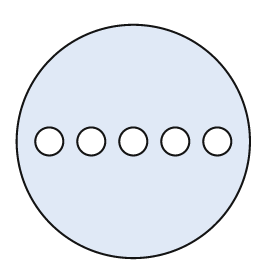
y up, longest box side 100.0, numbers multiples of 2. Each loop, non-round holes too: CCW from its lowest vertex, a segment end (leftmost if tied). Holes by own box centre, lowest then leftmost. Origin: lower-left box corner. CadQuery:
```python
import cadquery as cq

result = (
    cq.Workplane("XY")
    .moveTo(50.0, 50.0)
    .circle(50.0)
    .moveTo(14.0, 50.0)
    .circle(6.0)
    .moveTo(32.0, 50.0)
    .circle(6.0)
    .moveTo(50.0, 50.0)
    .circle(6.0)
    .moveTo(68.0, 50.0)
    .circle(6.0)
    .moveTo(86.0, 50.0)
    .circle(6.0)
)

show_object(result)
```